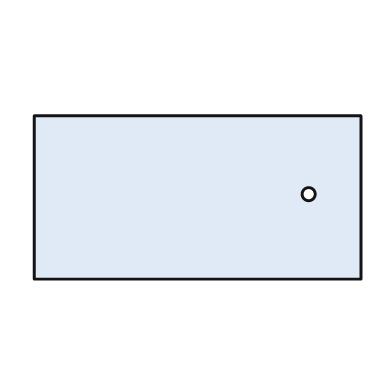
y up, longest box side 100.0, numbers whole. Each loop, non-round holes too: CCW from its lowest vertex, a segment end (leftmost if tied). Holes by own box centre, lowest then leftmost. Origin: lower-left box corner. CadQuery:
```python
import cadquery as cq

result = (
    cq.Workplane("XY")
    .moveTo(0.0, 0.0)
    .lineTo(100.0, 0.0)
    .lineTo(100.0, 50.0)
    .lineTo(0.0, 50.0)
    .close()
    .moveTo(84.0, 26.0)
    .circle(2.0)
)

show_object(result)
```